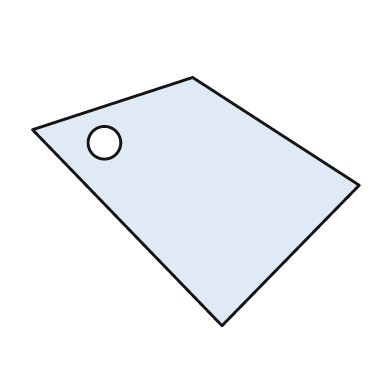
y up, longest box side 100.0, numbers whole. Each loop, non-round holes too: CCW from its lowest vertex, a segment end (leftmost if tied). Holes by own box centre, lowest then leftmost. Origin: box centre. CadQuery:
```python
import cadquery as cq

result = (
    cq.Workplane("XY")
    .moveTo(8.0, -38.0)
    .lineTo(50.0, 5.0)
    .lineTo(-1.0, 38.0)
    .lineTo(-50.0, 22.0)
    .close()
    .moveTo(-28.0, 18.0)
    .circle(5.0)
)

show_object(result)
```